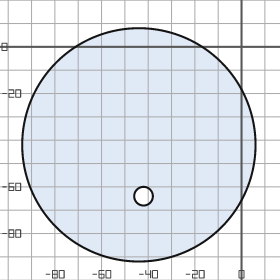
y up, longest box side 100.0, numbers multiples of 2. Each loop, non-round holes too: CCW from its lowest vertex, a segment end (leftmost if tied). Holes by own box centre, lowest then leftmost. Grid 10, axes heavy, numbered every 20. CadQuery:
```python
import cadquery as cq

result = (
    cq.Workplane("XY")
    .moveTo(-44.0, -42.0)
    .circle(50.0)
    .moveTo(-42.0, -64.0)
    .circle(4.0)
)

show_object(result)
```